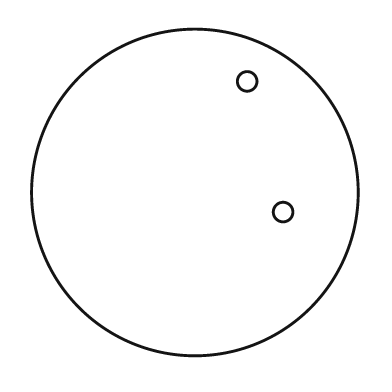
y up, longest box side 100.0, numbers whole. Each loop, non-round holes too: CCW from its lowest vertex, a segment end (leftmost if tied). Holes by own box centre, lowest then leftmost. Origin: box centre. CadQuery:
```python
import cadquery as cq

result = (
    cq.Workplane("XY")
    .moveTo(0.0, 0.0)
    .circle(50.0)
    .moveTo(27.0, -6.0)
    .circle(3.0)
    .moveTo(16.0, 34.0)
    .circle(3.0)
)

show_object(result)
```